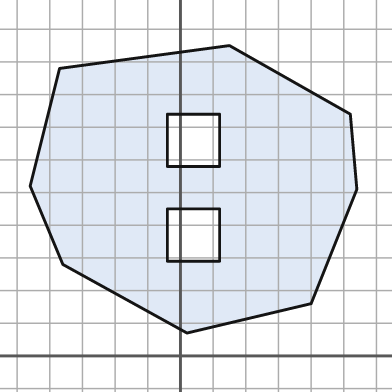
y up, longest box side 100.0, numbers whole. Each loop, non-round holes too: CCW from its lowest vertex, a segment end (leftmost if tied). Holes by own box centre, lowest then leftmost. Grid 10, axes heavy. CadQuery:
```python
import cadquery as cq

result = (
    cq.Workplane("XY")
    .moveTo(2.0, 7.0)
    .lineTo(40.0, 16.0)
    .lineTo(54.0, 51.0)
    .lineTo(52.0, 74.0)
    .lineTo(15.0, 95.0)
    .lineTo(-37.0, 88.0)
    .lineTo(-46.0, 52.0)
    .lineTo(-36.0, 28.0)
    .close()
    .moveTo(-4.0, 29.0)
    .lineTo(12.0, 29.0)
    .lineTo(12.0, 45.0)
    .lineTo(-4.0, 45.0)
    .close()
    .moveTo(-4.0, 58.0)
    .lineTo(12.0, 58.0)
    .lineTo(12.0, 74.0)
    .lineTo(-4.0, 74.0)
    .close()
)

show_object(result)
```